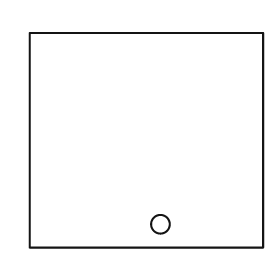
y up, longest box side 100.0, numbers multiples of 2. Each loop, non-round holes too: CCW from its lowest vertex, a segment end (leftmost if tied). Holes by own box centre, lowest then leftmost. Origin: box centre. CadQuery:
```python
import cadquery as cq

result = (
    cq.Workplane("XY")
    .moveTo(-50.0, -46.0)
    .lineTo(50.0, -46.0)
    .lineTo(50.0, 46.0)
    .lineTo(-50.0, 46.0)
    .close()
    .moveTo(6.0, -36.0)
    .circle(4.0)
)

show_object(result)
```